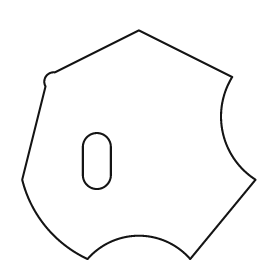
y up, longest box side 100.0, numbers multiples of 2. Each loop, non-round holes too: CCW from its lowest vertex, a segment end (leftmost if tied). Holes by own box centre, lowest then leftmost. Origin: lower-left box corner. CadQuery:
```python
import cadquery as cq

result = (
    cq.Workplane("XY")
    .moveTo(28.0, 0.0)
    .threePointArc((50.0, 10.0), (72.0, 0.0))
    .lineTo(100.0, 34.0)
    .threePointArc((86.0, 54.0), (90.0, 78.0))
    .lineTo(50.0, 98.0)
    .lineTo(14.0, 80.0)
    .threePointArc((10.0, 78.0), (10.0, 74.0))
    .lineTo(0.0, 34.0)
    .threePointArc((10.0, 14.0), (28.0, 0.0))
    .close()
    .moveTo(26.0, 36.0)
    .threePointArc((32.0, 30.0), (38.0, 36.0))
    .lineTo(38.0, 48.0)
    .threePointArc((32.0, 54.0), (26.0, 48.0))
    .close()
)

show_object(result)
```